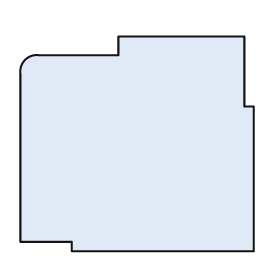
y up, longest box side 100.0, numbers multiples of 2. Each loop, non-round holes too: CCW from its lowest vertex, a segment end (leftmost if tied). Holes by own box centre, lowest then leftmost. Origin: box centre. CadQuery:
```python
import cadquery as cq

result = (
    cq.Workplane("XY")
    .moveTo(-28.0, -46.0)
    .lineTo(50.0, -46.0)
    .lineTo(50.0, 16.0)
    .lineTo(46.0, 16.0)
    .lineTo(46.0, 46.0)
    .lineTo(-8.0, 46.0)
    .lineTo(-8.0, 38.0)
    .lineTo(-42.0, 38.0)
    .threePointArc((-48.0, 36.0), (-50.0, 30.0))
    .lineTo(-50.0, -42.0)
    .lineTo(-28.0, -42.0)
    .close()
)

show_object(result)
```